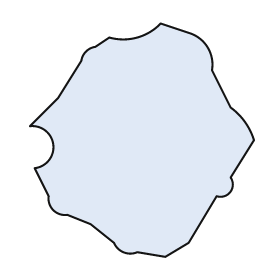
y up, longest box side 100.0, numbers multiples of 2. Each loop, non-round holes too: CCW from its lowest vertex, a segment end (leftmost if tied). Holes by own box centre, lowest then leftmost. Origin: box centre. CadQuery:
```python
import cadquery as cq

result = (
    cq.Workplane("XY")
    .moveTo(10.0, -50.0)
    .lineTo(20.0, -44.0)
    .lineTo(32.0, -24.0)
    .threePointArc((38.0, -22.0), (38.0, -16.0))
    .lineTo(48.0, 0.0)
    .threePointArc((44.0, 8.0), (38.0, 14.0))
    .lineTo(30.0, 30.0)
    .threePointArc((28.0, 40.0), (20.0, 46.0))
    .lineTo(8.0, 50.0)
    .threePointArc((-2.0, 44.0), (-14.0, 44.0))
    .lineTo(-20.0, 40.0)
    .threePointArc((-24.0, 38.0), (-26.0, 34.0))
    .lineTo(-36.0, 18.0)
    .lineTo(-48.0, 6.0)
    .threePointArc((-38.0, -2.0), (-46.0, -12.0))
    .lineTo(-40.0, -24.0)
    .threePointArc((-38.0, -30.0), (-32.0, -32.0))
    .lineTo(-22.0, -36.0)
    .lineTo(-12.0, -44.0)
    .threePointArc((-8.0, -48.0), (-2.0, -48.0))
    .close()
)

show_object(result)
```